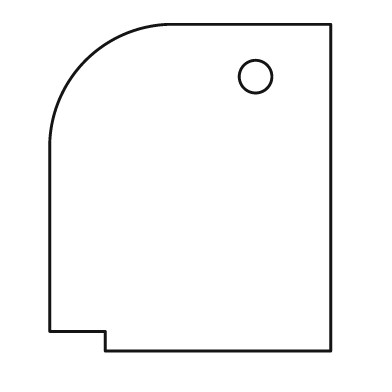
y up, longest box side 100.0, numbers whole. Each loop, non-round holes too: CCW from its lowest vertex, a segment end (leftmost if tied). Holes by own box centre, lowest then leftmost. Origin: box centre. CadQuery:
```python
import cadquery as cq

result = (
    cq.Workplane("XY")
    .moveTo(-26.0, -50.0)
    .lineTo(43.0, -50.0)
    .lineTo(43.0, 50.0)
    .lineTo(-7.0, 50.0)
    .threePointArc((-32.0, 39.0), (-43.0, 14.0))
    .lineTo(-43.0, -44.0)
    .lineTo(-26.0, -44.0)
    .close()
    .moveTo(20.0, 34.0)
    .circle(5.0)
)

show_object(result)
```